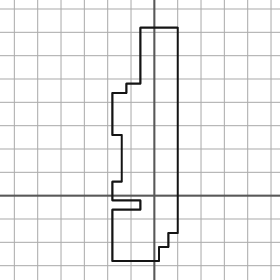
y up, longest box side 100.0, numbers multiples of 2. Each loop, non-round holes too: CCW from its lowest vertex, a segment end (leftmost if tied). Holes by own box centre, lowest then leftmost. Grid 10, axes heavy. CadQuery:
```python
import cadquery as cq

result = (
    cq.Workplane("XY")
    .moveTo(-18.0, -28.0)
    .lineTo(2.0, -28.0)
    .lineTo(2.0, -22.0)
    .lineTo(6.0, -22.0)
    .lineTo(6.0, -16.0)
    .lineTo(10.0, -16.0)
    .lineTo(10.0, 72.0)
    .lineTo(-6.0, 72.0)
    .lineTo(-6.0, 48.0)
    .lineTo(-12.0, 48.0)
    .lineTo(-12.0, 44.0)
    .lineTo(-18.0, 44.0)
    .lineTo(-18.0, 26.0)
    .lineTo(-14.0, 26.0)
    .lineTo(-14.0, 6.0)
    .lineTo(-18.0, 6.0)
    .lineTo(-18.0, -2.0)
    .lineTo(-6.0, -2.0)
    .lineTo(-6.0, -6.0)
    .lineTo(-18.0, -6.0)
    .close()
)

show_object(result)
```